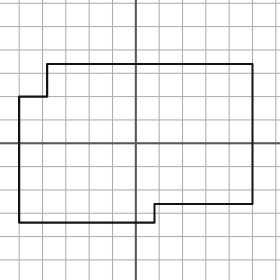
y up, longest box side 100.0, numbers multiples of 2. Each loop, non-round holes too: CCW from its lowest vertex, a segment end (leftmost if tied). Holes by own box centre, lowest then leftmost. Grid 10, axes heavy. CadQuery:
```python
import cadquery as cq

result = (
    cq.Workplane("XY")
    .moveTo(-50.0, -34.0)
    .lineTo(8.0, -34.0)
    .lineTo(8.0, -26.0)
    .lineTo(50.0, -26.0)
    .lineTo(50.0, 34.0)
    .lineTo(-38.0, 34.0)
    .lineTo(-38.0, 20.0)
    .lineTo(-50.0, 20.0)
    .close()
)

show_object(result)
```